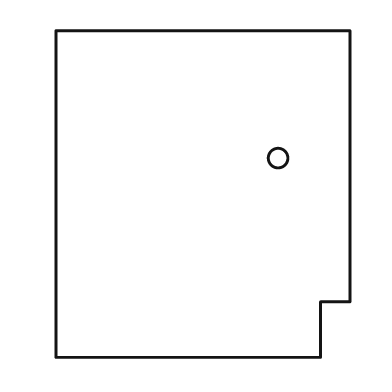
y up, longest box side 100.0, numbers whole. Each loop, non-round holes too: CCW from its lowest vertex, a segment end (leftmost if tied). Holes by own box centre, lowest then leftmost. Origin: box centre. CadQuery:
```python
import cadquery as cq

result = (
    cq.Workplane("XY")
    .moveTo(-45.0, -50.0)
    .lineTo(36.0, -50.0)
    .lineTo(36.0, -33.0)
    .lineTo(45.0, -33.0)
    .lineTo(45.0, 50.0)
    .lineTo(-45.0, 50.0)
    .close()
    .moveTo(23.0, 11.0)
    .circle(3.0)
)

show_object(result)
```